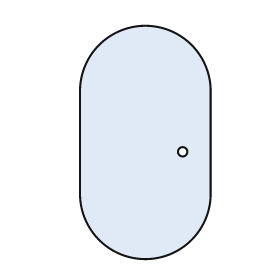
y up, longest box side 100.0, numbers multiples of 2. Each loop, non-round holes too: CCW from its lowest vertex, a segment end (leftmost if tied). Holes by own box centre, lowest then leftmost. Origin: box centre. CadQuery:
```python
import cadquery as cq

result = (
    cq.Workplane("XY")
    .moveTo(-28.0, -22.0)
    .threePointArc((0.0, -50.0), (28.0, -22.0))
    .lineTo(28.0, 22.0)
    .threePointArc((0.0, 50.0), (-28.0, 22.0))
    .close()
    .moveTo(16.0, -4.0)
    .circle(2.0)
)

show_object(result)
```